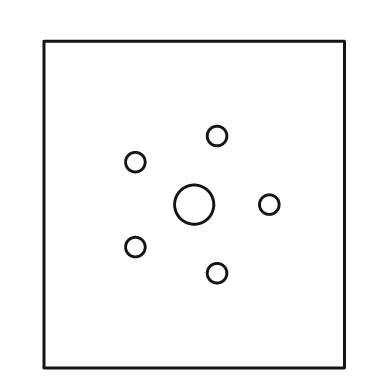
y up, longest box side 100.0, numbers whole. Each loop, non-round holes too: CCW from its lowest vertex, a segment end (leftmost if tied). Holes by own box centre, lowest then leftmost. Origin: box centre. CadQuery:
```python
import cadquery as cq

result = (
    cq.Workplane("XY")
    .moveTo(-46.0, -50.0)
    .lineTo(46.0, -50.0)
    .lineTo(46.0, 50.0)
    .lineTo(-46.0, 50.0)
    .close()
    .moveTo(7.0, -21.0)
    .circle(3.0)
    .moveTo(-18.0, -13.0)
    .circle(3.0)
    .moveTo(0.0, 0.0)
    .circle(6.0)
    .moveTo(23.0, 0.0)
    .circle(3.0)
    .moveTo(-18.0, 13.0)
    .circle(3.0)
    .moveTo(7.0, 21.0)
    .circle(3.0)
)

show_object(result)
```